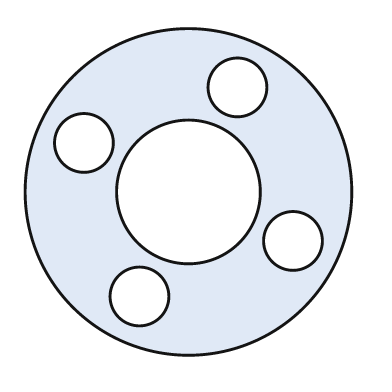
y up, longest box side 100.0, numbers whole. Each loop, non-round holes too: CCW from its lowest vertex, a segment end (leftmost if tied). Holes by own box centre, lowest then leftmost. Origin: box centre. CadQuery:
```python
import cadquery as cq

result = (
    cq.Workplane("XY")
    .moveTo(0.0, 0.0)
    .circle(50.0)
    .moveTo(-15.0, -32.0)
    .circle(9.0)
    .moveTo(32.0, -15.0)
    .circle(9.0)
    .moveTo(0.0, 0.0)
    .circle(22.0)
    .moveTo(-32.0, 15.0)
    .circle(9.0)
    .moveTo(15.0, 32.0)
    .circle(9.0)
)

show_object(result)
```